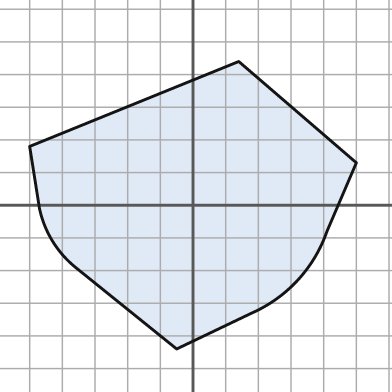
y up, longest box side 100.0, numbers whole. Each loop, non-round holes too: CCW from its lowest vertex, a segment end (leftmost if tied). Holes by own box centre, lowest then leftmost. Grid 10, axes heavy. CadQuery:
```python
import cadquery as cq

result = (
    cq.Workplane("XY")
    .moveTo(-5.0, -44.0)
    .lineTo(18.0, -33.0)
    .threePointArc((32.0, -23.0), (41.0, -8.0))
    .lineTo(50.0, 13.0)
    .lineTo(14.0, 44.0)
    .lineTo(-50.0, 18.0)
    .lineTo(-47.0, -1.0)
    .threePointArc((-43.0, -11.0), (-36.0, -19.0))
    .close()
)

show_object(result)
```